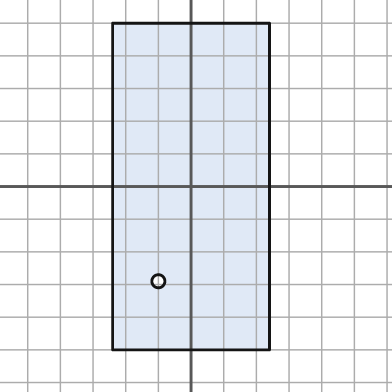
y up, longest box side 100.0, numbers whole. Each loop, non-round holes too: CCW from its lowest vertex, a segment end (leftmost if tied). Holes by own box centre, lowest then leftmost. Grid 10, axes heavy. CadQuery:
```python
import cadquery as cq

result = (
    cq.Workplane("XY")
    .moveTo(-24.0, -50.0)
    .lineTo(24.0, -50.0)
    .lineTo(24.0, 50.0)
    .lineTo(-24.0, 50.0)
    .close()
    .moveTo(-10.0, -29.0)
    .circle(2.0)
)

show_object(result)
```